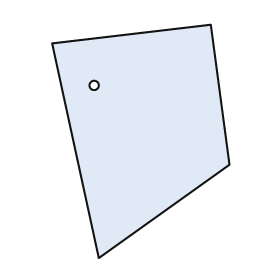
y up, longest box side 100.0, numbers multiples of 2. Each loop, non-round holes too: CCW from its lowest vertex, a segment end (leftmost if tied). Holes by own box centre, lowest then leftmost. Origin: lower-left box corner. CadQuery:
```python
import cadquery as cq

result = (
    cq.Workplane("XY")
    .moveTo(20.0, 0.0)
    .lineTo(76.0, 40.0)
    .lineTo(68.0, 100.0)
    .lineTo(0.0, 92.0)
    .close()
    .moveTo(18.0, 74.0)
    .circle(2.0)
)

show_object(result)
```